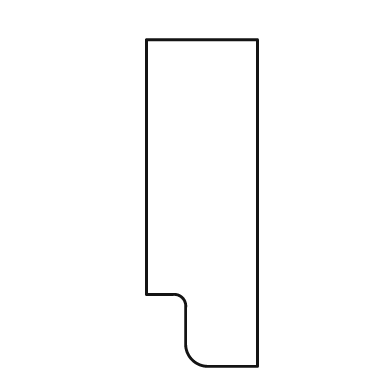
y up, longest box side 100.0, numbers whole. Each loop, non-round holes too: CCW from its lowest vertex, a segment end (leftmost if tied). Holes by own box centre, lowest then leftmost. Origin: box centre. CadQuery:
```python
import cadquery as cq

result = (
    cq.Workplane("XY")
    .moveTo(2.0, -50.0)
    .lineTo(17.0, -50.0)
    .lineTo(17.0, 50.0)
    .lineTo(-17.0, 50.0)
    .lineTo(-17.0, -28.0)
    .lineTo(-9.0, -28.0)
    .threePointArc((-6.0, -29.0), (-5.0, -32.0))
    .lineTo(-5.0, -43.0)
    .threePointArc((-3.0, -48.0), (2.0, -50.0))
    .close()
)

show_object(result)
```